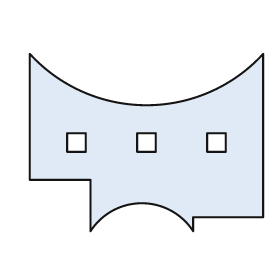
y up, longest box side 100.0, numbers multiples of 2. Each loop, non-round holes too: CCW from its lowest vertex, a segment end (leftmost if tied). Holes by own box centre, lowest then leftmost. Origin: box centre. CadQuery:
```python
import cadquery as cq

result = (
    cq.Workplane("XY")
    .moveTo(-24.0, -38.0)
    .threePointArc((-2.0, -26.0), (20.0, -38.0))
    .lineTo(20.0, -32.0)
    .lineTo(50.0, -32.0)
    .lineTo(50.0, 38.0)
    .threePointArc((0.0, 16.0), (-50.0, 38.0))
    .lineTo(-50.0, -16.0)
    .lineTo(-24.0, -16.0)
    .close()
    .moveTo(-34.0, -4.0)
    .lineTo(-26.0, -4.0)
    .lineTo(-26.0, 4.0)
    .lineTo(-34.0, 4.0)
    .close()
    .moveTo(-4.0, -4.0)
    .lineTo(4.0, -4.0)
    .lineTo(4.0, 4.0)
    .lineTo(-4.0, 4.0)
    .close()
    .moveTo(26.0, -4.0)
    .lineTo(34.0, -4.0)
    .lineTo(34.0, 4.0)
    .lineTo(26.0, 4.0)
    .close()
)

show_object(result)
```